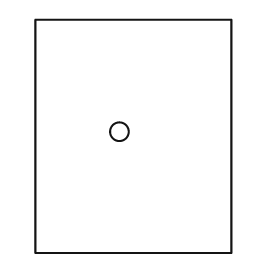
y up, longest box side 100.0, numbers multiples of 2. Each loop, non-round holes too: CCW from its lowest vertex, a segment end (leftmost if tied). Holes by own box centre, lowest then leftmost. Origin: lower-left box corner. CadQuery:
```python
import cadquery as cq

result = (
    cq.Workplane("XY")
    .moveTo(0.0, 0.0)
    .lineTo(84.0, 0.0)
    .lineTo(84.0, 100.0)
    .lineTo(0.0, 100.0)
    .close()
    .moveTo(36.0, 52.0)
    .circle(4.0)
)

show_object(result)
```